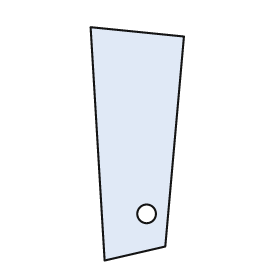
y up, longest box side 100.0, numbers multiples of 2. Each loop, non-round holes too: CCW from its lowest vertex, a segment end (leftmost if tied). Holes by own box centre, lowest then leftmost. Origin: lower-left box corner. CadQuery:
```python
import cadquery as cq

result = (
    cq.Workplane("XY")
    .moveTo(6.0, 0.0)
    .lineTo(32.0, 6.0)
    .lineTo(40.0, 96.0)
    .lineTo(0.0, 100.0)
    .close()
    .moveTo(24.0, 20.0)
    .circle(4.0)
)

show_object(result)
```